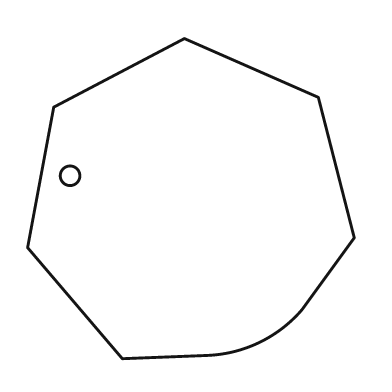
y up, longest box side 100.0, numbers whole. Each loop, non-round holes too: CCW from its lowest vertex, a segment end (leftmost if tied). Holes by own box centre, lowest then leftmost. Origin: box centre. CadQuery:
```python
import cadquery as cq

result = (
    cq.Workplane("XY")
    .moveTo(-21.0, -49.0)
    .lineTo(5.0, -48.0)
    .threePointArc((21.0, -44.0), (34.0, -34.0))
    .lineTo(50.0, -12.0)
    .lineTo(39.0, 31.0)
    .lineTo(-2.0, 49.0)
    .lineTo(-42.0, 28.0)
    .lineTo(-50.0, -15.0)
    .close()
    .moveTo(-37.0, 7.0)
    .circle(3.0)
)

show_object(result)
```